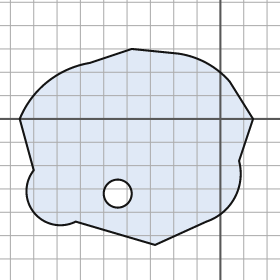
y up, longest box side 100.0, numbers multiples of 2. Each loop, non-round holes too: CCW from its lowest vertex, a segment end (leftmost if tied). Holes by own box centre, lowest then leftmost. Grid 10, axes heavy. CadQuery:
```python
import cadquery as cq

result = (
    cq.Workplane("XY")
    .moveTo(-28.0, -54.0)
    .lineTo(-6.0, -44.0)
    .threePointArc((6.0, -34.0), (8.0, -18.0))
    .lineTo(14.0, 0.0)
    .lineTo(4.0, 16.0)
    .threePointArc((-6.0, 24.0), (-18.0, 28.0))
    .lineTo(-38.0, 30.0)
    .lineTo(-56.0, 24.0)
    .threePointArc((-74.0, 16.0), (-86.0, 0.0))
    .lineTo(-80.0, -22.0)
    .threePointArc((-80.0, -40.0), (-62.0, -44.0))
    .close()
    .moveTo(-44.0, -32.0)
    .circle(6.0)
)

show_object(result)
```